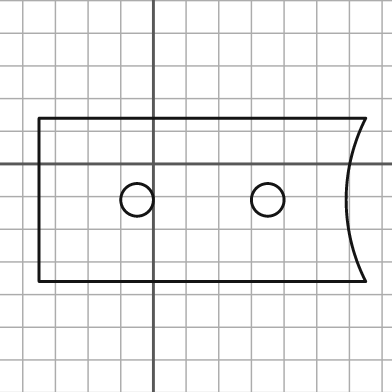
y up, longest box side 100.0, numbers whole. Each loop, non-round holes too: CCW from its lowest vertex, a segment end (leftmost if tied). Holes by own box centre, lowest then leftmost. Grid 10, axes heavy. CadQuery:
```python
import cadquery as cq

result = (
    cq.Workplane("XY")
    .moveTo(-35.0, -36.0)
    .lineTo(65.0, -36.0)
    .threePointArc((59.0, -11.0), (65.0, 14.0))
    .lineTo(-35.0, 14.0)
    .close()
    .moveTo(-5.0, -11.0)
    .circle(5.0)
    .moveTo(35.0, -11.0)
    .circle(5.0)
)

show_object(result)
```